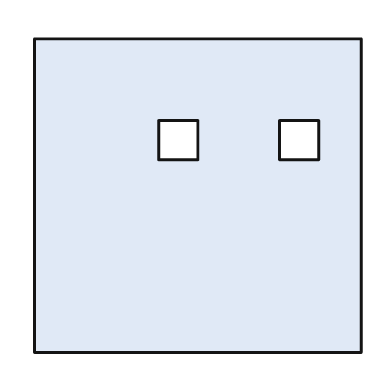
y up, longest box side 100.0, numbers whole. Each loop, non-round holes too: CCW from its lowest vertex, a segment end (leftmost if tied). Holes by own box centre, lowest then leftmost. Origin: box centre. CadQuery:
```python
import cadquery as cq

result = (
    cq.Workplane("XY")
    .moveTo(-50.0, -48.0)
    .lineTo(50.0, -48.0)
    .lineTo(50.0, 48.0)
    .lineTo(-50.0, 48.0)
    .close()
    .moveTo(-12.0, 11.0)
    .lineTo(0.0, 11.0)
    .lineTo(0.0, 23.0)
    .lineTo(-12.0, 23.0)
    .close()
    .moveTo(25.0, 11.0)
    .lineTo(37.0, 11.0)
    .lineTo(37.0, 23.0)
    .lineTo(25.0, 23.0)
    .close()
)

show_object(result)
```